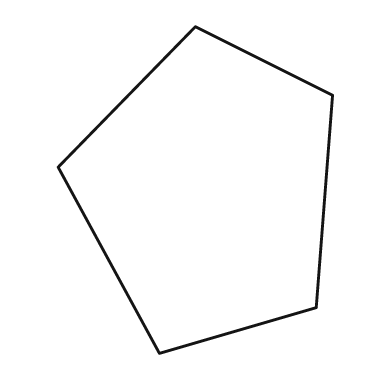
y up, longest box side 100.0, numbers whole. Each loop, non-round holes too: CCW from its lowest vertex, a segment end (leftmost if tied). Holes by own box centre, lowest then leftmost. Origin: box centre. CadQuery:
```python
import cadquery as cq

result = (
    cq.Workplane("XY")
    .moveTo(-11.0, -50.0)
    .lineTo(37.0, -36.0)
    .lineTo(42.0, 29.0)
    .lineTo(0.0, 50.0)
    .lineTo(-42.0, 7.0)
    .close()
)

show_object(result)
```